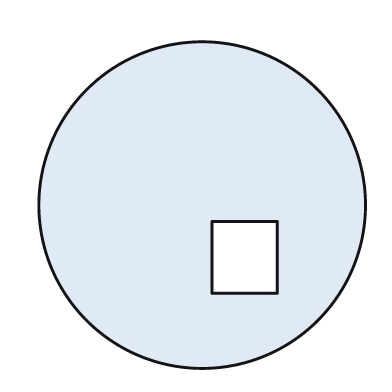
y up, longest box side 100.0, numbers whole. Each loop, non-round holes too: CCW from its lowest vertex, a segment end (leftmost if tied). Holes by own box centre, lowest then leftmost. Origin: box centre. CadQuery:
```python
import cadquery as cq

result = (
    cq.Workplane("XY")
    .moveTo(0.0, 0.0)
    .circle(50.0)
    .moveTo(3.0, -27.0)
    .lineTo(23.0, -27.0)
    .lineTo(23.0, -5.0)
    .lineTo(3.0, -5.0)
    .close()
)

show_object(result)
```